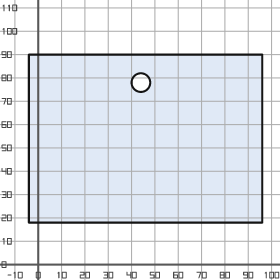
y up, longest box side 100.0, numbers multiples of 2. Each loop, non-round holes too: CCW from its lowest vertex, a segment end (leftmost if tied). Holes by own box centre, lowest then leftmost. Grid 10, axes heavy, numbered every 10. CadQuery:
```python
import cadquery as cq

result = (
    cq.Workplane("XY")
    .moveTo(-4.0, 18.0)
    .lineTo(96.0, 18.0)
    .lineTo(96.0, 90.0)
    .lineTo(-4.0, 90.0)
    .close()
    .moveTo(44.0, 78.0)
    .circle(4.0)
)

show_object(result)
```